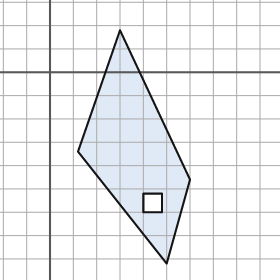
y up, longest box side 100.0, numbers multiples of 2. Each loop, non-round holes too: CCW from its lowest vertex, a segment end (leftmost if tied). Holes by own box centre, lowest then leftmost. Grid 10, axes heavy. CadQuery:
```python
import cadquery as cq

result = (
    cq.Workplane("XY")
    .moveTo(50.0, -82.0)
    .lineTo(60.0, -46.0)
    .lineTo(30.0, 18.0)
    .lineTo(12.0, -34.0)
    .close()
    .moveTo(40.0, -60.0)
    .lineTo(48.0, -60.0)
    .lineTo(48.0, -52.0)
    .lineTo(40.0, -52.0)
    .close()
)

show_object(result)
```